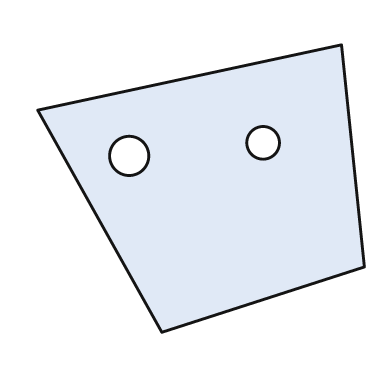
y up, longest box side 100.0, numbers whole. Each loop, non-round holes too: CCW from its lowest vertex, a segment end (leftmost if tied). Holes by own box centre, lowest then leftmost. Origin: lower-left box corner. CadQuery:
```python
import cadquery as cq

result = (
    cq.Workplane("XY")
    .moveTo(38.0, 0.0)
    .lineTo(100.0, 20.0)
    .lineTo(93.0, 88.0)
    .lineTo(0.0, 68.0)
    .close()
    .moveTo(28.0, 54.0)
    .circle(6.0)
    .moveTo(69.0, 58.0)
    .circle(5.0)
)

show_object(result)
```